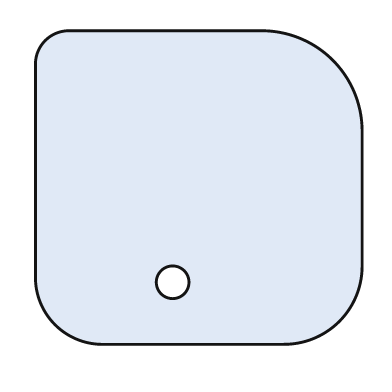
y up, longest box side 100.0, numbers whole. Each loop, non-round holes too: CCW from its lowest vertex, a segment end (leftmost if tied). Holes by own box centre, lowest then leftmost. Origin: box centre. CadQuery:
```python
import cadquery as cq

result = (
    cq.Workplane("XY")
    .moveTo(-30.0, -48.0)
    .lineTo(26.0, -48.0)
    .threePointArc((43.0, -41.0), (50.0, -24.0))
    .lineTo(50.0, 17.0)
    .threePointArc((41.0, 39.0), (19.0, 48.0))
    .lineTo(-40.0, 48.0)
    .threePointArc((-47.0, 45.0), (-50.0, 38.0))
    .lineTo(-50.0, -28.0)
    .threePointArc((-44.0, -42.0), (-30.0, -48.0))
    .close()
    .moveTo(-8.0, -29.0)
    .circle(5.0)
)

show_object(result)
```